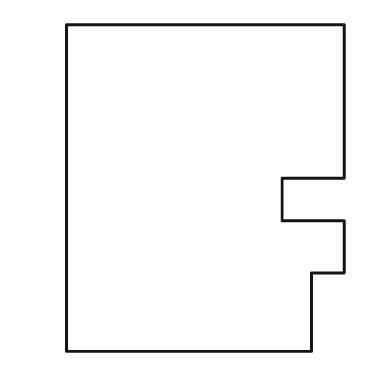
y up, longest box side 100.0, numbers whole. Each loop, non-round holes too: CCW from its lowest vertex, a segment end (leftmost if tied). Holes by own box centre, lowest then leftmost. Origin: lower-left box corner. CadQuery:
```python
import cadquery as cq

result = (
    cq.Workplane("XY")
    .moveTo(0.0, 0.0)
    .lineTo(75.0, 0.0)
    .lineTo(75.0, 24.0)
    .lineTo(85.0, 24.0)
    .lineTo(85.0, 40.0)
    .lineTo(66.0, 40.0)
    .lineTo(66.0, 53.0)
    .lineTo(85.0, 53.0)
    .lineTo(85.0, 100.0)
    .lineTo(0.0, 100.0)
    .close()
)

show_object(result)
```